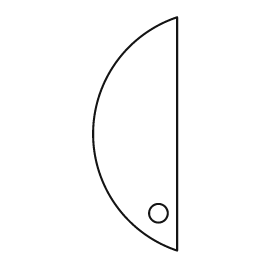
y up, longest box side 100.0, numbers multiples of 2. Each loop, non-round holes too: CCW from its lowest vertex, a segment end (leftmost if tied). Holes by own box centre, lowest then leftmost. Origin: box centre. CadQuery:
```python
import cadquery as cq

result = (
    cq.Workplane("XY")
    .moveTo(18.0, -50.0)
    .lineTo(18.0, 50.0)
    .threePointArc((-18.0, 0.0), (18.0, -50.0))
    .close()
    .moveTo(10.0, -34.0)
    .circle(4.0)
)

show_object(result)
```